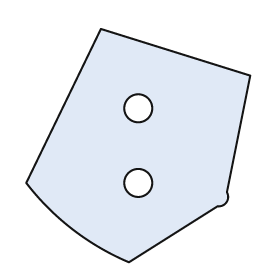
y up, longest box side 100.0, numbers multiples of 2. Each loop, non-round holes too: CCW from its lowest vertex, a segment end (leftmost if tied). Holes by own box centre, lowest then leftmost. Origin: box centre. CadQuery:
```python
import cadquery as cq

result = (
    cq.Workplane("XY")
    .moveTo(-4.0, -50.0)
    .lineTo(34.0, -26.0)
    .threePointArc((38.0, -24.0), (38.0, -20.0))
    .lineTo(48.0, 30.0)
    .lineTo(-16.0, 50.0)
    .lineTo(-48.0, -16.0)
    .threePointArc((-28.0, -36.0), (-4.0, -50.0))
    .close()
    .moveTo(0.0, -16.0)
    .circle(6.0)
    .moveTo(0.0, 16.0)
    .circle(6.0)
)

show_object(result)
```